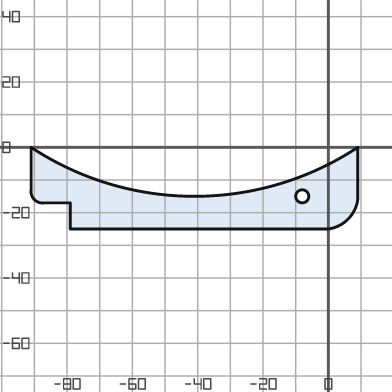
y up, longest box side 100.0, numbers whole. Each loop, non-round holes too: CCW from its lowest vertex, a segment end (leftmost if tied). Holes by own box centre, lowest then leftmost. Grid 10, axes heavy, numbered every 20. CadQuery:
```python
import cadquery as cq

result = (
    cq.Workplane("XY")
    .moveTo(-79.0, -25.0)
    .lineTo(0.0, -25.0)
    .threePointArc((6.0, -22.0), (9.0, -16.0))
    .lineTo(9.0, 0.0)
    .threePointArc((-41.0, -15.0), (-91.0, 0.0))
    .lineTo(-91.0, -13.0)
    .threePointArc((-90.0, -16.0), (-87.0, -17.0))
    .lineTo(-79.0, -17.0)
    .close()
    .moveTo(-8.0, -15.0)
    .circle(2.0)
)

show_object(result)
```